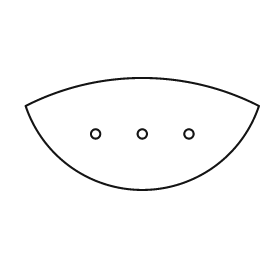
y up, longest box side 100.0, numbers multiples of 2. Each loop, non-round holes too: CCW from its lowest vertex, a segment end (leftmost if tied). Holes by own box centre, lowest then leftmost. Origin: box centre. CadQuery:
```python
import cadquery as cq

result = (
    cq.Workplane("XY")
    .moveTo(-50.0, 12.0)
    .threePointArc((0.0, -24.0), (50.0, 12.0))
    .threePointArc((0.0, 24.0), (-50.0, 12.0))
    .close()
    .moveTo(-20.0, 0.0)
    .circle(2.0)
    .moveTo(0.0, 0.0)
    .circle(2.0)
    .moveTo(20.0, 0.0)
    .circle(2.0)
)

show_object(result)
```